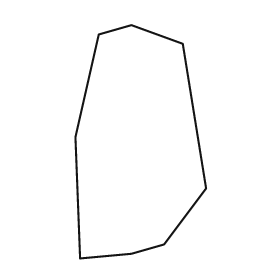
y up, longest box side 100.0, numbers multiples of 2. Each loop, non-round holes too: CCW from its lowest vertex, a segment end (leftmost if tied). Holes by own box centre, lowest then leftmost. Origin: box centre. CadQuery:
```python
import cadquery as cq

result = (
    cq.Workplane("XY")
    .moveTo(-26.0, -50.0)
    .lineTo(-4.0, -48.0)
    .lineTo(10.0, -44.0)
    .lineTo(28.0, -20.0)
    .lineTo(18.0, 42.0)
    .lineTo(-4.0, 50.0)
    .lineTo(-18.0, 46.0)
    .lineTo(-28.0, 2.0)
    .close()
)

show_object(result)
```